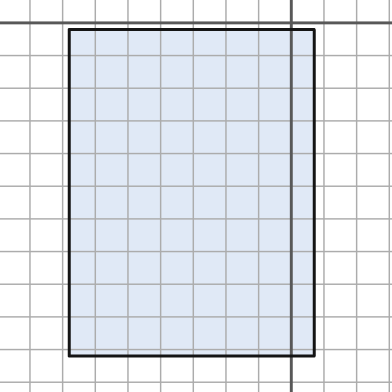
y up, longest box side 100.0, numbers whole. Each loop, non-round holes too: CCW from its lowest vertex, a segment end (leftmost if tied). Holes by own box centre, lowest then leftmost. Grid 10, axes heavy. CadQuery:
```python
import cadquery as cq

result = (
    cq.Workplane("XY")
    .moveTo(-68.0, -102.0)
    .lineTo(7.0, -102.0)
    .lineTo(7.0, -2.0)
    .lineTo(-68.0, -2.0)
    .close()
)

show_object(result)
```